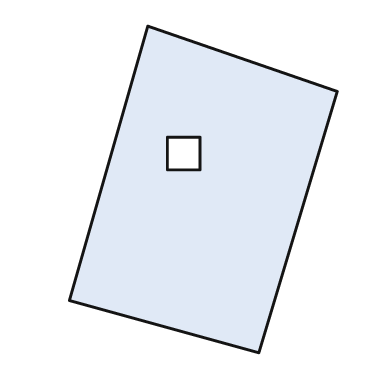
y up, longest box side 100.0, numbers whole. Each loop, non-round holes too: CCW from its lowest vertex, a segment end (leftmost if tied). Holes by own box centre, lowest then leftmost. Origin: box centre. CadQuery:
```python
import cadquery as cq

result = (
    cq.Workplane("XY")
    .moveTo(17.0, -50.0)
    .lineTo(41.0, 30.0)
    .lineTo(-17.0, 50.0)
    .lineTo(-41.0, -34.0)
    .close()
    .moveTo(-11.0, 6.0)
    .lineTo(-1.0, 6.0)
    .lineTo(-1.0, 16.0)
    .lineTo(-11.0, 16.0)
    .close()
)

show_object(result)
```